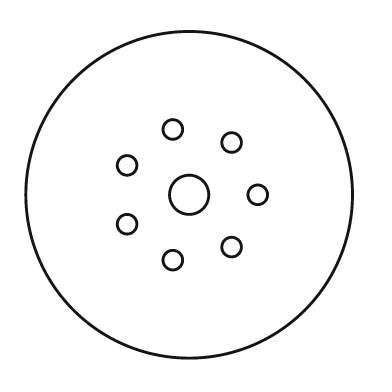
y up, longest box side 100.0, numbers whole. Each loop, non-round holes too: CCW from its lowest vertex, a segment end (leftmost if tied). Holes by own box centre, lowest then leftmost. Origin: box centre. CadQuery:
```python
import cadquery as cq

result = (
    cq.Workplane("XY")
    .moveTo(0.0, 0.0)
    .circle(50.0)
    .moveTo(-5.0, -20.0)
    .circle(3.0)
    .moveTo(13.0, -16.0)
    .circle(3.0)
    .moveTo(-19.0, -9.0)
    .circle(3.0)
    .moveTo(0.0, 0.0)
    .circle(6.0)
    .moveTo(21.0, 0.0)
    .circle(3.0)
    .moveTo(-19.0, 9.0)
    .circle(3.0)
    .moveTo(13.0, 16.0)
    .circle(3.0)
    .moveTo(-5.0, 20.0)
    .circle(3.0)
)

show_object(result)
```